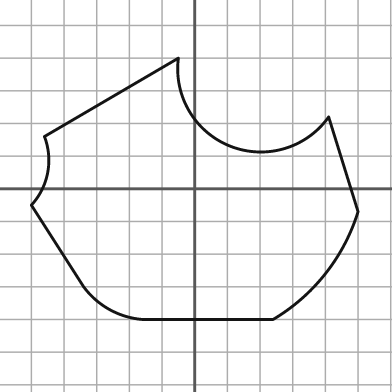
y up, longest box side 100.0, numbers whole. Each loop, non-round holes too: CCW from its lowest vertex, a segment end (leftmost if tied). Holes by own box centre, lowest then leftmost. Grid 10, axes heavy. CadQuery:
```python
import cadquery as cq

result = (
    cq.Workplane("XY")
    .moveTo(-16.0, -40.0)
    .lineTo(24.0, -40.0)
    .threePointArc((40.0, -26.0), (50.0, -7.0))
    .lineTo(41.0, 22.0)
    .threePointArc((11.0, 13.0), (-5.0, 40.0))
    .lineTo(-46.0, 16.0)
    .threePointArc((-45.0, 5.0), (-50.0, -5.0))
    .lineTo(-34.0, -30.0)
    .threePointArc((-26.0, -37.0), (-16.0, -40.0))
    .close()
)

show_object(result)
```